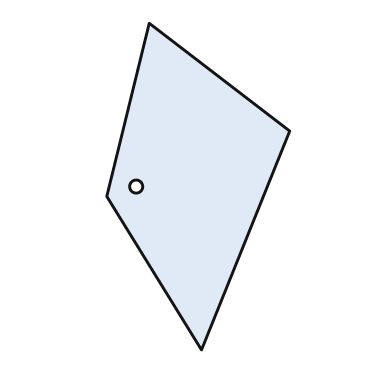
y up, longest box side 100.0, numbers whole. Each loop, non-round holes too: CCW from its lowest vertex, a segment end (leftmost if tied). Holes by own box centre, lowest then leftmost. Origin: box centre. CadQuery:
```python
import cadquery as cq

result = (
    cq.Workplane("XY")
    .moveTo(1.0, -50.0)
    .lineTo(28.0, 17.0)
    .lineTo(-15.0, 50.0)
    .lineTo(-28.0, -3.0)
    .close()
    .moveTo(-19.0, 0.0)
    .circle(2.0)
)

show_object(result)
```